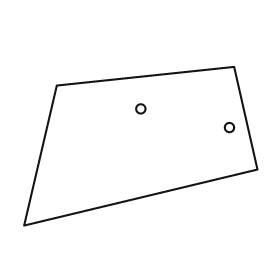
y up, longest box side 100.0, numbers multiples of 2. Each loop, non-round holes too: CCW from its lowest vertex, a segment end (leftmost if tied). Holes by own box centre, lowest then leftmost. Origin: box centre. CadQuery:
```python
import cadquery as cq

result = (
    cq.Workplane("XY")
    .moveTo(-50.0, -34.0)
    .lineTo(50.0, -10.0)
    .lineTo(40.0, 34.0)
    .lineTo(-36.0, 26.0)
    .close()
    .moveTo(38.0, 8.0)
    .circle(2.0)
    .moveTo(0.0, 16.0)
    .circle(2.0)
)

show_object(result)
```